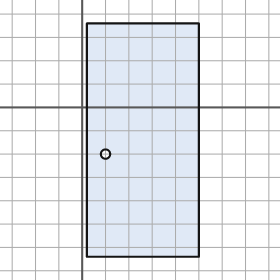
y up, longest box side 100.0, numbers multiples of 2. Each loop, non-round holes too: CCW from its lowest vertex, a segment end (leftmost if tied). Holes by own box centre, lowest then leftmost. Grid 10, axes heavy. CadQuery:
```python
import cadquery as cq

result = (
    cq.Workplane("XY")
    .moveTo(2.0, -64.0)
    .lineTo(50.0, -64.0)
    .lineTo(50.0, 36.0)
    .lineTo(2.0, 36.0)
    .close()
    .moveTo(10.0, -20.0)
    .circle(2.0)
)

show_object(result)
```